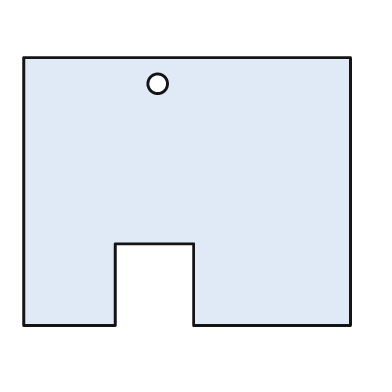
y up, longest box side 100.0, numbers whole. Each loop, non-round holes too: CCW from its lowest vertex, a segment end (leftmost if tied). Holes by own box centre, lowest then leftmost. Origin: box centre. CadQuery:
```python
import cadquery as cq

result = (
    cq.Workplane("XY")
    .moveTo(-50.0, -41.0)
    .lineTo(-22.0, -41.0)
    .lineTo(-22.0, -16.0)
    .lineTo(2.0, -16.0)
    .lineTo(2.0, -41.0)
    .lineTo(50.0, -41.0)
    .lineTo(50.0, 41.0)
    .lineTo(-50.0, 41.0)
    .close()
    .moveTo(-9.0, 33.0)
    .circle(3.0)
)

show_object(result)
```